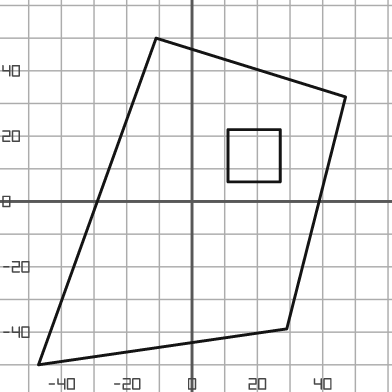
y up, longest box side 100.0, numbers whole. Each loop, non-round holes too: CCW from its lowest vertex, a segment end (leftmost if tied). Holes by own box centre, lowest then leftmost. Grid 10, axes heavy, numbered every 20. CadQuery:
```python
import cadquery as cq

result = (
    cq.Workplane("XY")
    .moveTo(-47.0, -50.0)
    .lineTo(29.0, -39.0)
    .lineTo(47.0, 32.0)
    .lineTo(-11.0, 50.0)
    .close()
    .moveTo(11.0, 6.0)
    .lineTo(27.0, 6.0)
    .lineTo(27.0, 22.0)
    .lineTo(11.0, 22.0)
    .close()
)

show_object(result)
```